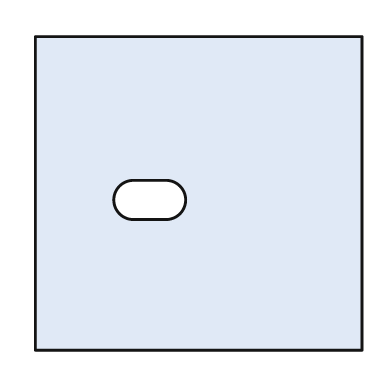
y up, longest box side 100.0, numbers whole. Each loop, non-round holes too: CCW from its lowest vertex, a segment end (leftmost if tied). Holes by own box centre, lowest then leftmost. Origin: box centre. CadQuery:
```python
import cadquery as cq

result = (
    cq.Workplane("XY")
    .moveTo(-50.0, -48.0)
    .lineTo(50.0, -48.0)
    .lineTo(50.0, 48.0)
    .lineTo(-50.0, 48.0)
    .close()
    .moveTo(-20.0, -8.0)
    .lineTo(-10.0, -8.0)
    .threePointArc((-4.0, -2.0), (-10.0, 4.0))
    .lineTo(-20.0, 4.0)
    .threePointArc((-26.0, -2.0), (-20.0, -8.0))
    .close()
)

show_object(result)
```